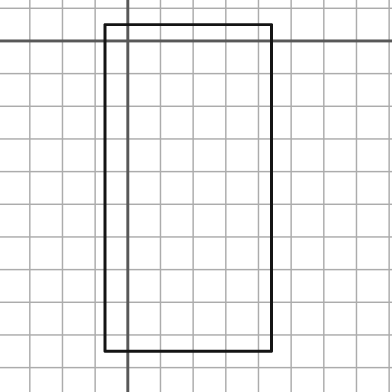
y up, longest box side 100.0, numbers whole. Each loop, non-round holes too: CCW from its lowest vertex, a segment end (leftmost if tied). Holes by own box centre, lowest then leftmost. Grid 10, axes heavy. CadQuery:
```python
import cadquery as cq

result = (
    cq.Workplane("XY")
    .moveTo(-7.0, -95.0)
    .lineTo(44.0, -95.0)
    .lineTo(44.0, 5.0)
    .lineTo(-7.0, 5.0)
    .close()
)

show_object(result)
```